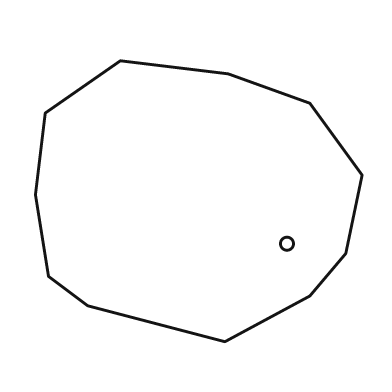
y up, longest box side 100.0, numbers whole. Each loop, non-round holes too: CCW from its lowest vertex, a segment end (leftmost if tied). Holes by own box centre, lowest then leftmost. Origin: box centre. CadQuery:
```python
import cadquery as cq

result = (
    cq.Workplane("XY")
    .moveTo(8.0, -43.0)
    .lineTo(34.0, -29.0)
    .lineTo(45.0, -16.0)
    .lineTo(50.0, 8.0)
    .lineTo(34.0, 30.0)
    .lineTo(9.0, 39.0)
    .lineTo(-24.0, 43.0)
    .lineTo(-47.0, 27.0)
    .lineTo(-50.0, 2.0)
    .lineTo(-46.0, -23.0)
    .lineTo(-34.0, -32.0)
    .close()
    .moveTo(27.0, -13.0)
    .circle(2.0)
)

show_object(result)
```